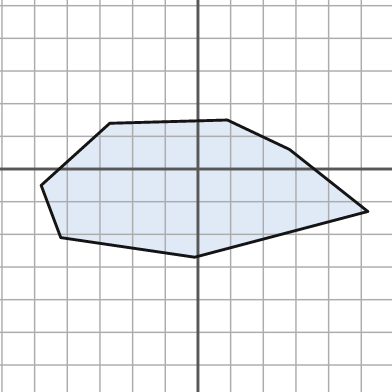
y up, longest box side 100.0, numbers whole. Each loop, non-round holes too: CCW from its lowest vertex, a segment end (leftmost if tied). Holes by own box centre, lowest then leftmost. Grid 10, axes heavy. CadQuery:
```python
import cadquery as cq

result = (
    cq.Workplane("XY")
    .moveTo(-1.0, -27.0)
    .lineTo(52.0, -13.0)
    .lineTo(28.0, 6.0)
    .lineTo(9.0, 15.0)
    .lineTo(-27.0, 14.0)
    .lineTo(-48.0, -5.0)
    .lineTo(-42.0, -21.0)
    .close()
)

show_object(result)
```